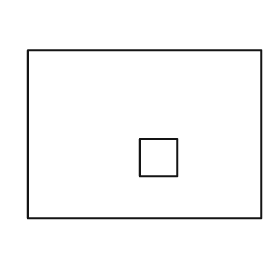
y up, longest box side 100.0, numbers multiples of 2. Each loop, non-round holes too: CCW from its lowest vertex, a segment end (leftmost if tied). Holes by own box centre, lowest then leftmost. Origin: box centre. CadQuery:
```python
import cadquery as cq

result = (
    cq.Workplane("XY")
    .moveTo(-50.0, -36.0)
    .lineTo(50.0, -36.0)
    .lineTo(50.0, 36.0)
    .lineTo(-50.0, 36.0)
    .close()
    .moveTo(-2.0, -18.0)
    .lineTo(14.0, -18.0)
    .lineTo(14.0, -2.0)
    .lineTo(-2.0, -2.0)
    .close()
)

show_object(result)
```